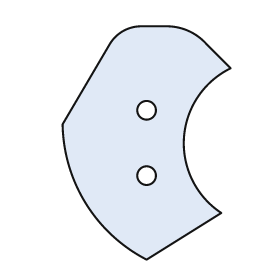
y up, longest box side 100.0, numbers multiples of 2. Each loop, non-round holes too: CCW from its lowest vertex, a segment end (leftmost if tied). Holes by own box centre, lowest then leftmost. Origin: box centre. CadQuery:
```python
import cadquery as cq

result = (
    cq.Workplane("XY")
    .moveTo(0.0, -50.0)
    .lineTo(32.0, -30.0)
    .threePointArc((16.0, 2.0), (36.0, 32.0))
    .lineTo(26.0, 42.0)
    .threePointArc((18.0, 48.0), (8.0, 50.0))
    .lineTo(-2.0, 50.0)
    .threePointArc((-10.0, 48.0), (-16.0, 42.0))
    .lineTo(-36.0, 8.0)
    .threePointArc((-26.0, -26.0), (0.0, -50.0))
    .close()
    .moveTo(0.0, -14.0)
    .circle(4.0)
    .moveTo(0.0, 14.0)
    .circle(4.0)
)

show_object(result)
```